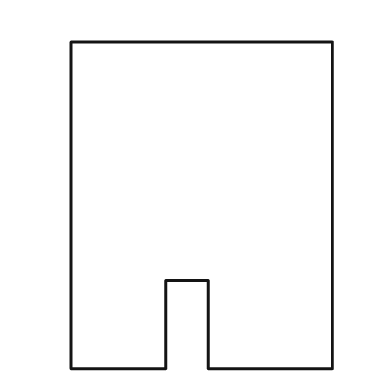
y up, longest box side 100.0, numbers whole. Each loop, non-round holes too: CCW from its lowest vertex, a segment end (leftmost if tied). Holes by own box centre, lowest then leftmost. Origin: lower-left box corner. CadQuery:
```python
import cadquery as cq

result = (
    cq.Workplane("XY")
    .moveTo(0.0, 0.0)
    .lineTo(29.0, 0.0)
    .lineTo(29.0, 27.0)
    .lineTo(42.0, 27.0)
    .lineTo(42.0, 0.0)
    .lineTo(80.0, 0.0)
    .lineTo(80.0, 100.0)
    .lineTo(0.0, 100.0)
    .close()
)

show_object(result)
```